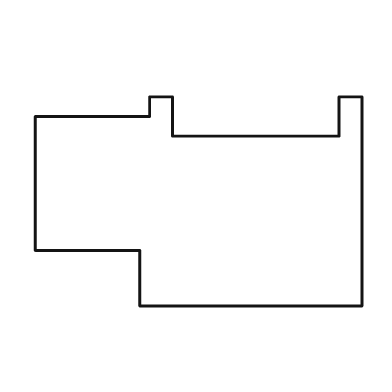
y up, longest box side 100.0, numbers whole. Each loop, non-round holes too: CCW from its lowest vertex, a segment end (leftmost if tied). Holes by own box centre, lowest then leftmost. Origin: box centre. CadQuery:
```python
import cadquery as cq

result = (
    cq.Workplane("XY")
    .moveTo(-18.0, -32.0)
    .lineTo(50.0, -32.0)
    .lineTo(50.0, 32.0)
    .lineTo(43.0, 32.0)
    .lineTo(43.0, 20.0)
    .lineTo(-8.0, 20.0)
    .lineTo(-8.0, 32.0)
    .lineTo(-15.0, 32.0)
    .lineTo(-15.0, 26.0)
    .lineTo(-50.0, 26.0)
    .lineTo(-50.0, -15.0)
    .lineTo(-18.0, -15.0)
    .close()
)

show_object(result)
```